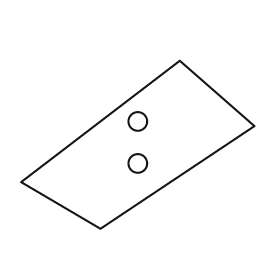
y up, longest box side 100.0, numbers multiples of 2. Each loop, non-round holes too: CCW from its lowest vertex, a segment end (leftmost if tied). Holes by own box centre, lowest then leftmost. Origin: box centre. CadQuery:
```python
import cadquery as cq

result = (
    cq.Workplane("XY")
    .moveTo(-16.0, -36.0)
    .lineTo(50.0, 8.0)
    .lineTo(18.0, 36.0)
    .lineTo(-50.0, -16.0)
    .close()
    .moveTo(0.0, -8.0)
    .circle(4.0)
    .moveTo(0.0, 10.0)
    .circle(4.0)
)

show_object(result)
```